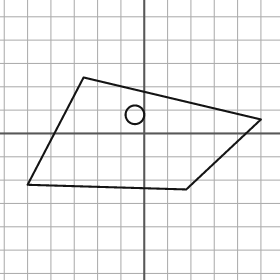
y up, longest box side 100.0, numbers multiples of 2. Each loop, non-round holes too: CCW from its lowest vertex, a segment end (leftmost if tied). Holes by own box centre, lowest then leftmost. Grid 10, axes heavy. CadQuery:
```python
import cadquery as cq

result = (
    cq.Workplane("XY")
    .moveTo(18.0, -24.0)
    .lineTo(50.0, 6.0)
    .lineTo(-26.0, 24.0)
    .lineTo(-50.0, -22.0)
    .close()
    .moveTo(-4.0, 8.0)
    .circle(4.0)
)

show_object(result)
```